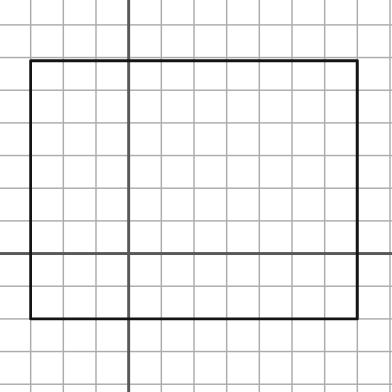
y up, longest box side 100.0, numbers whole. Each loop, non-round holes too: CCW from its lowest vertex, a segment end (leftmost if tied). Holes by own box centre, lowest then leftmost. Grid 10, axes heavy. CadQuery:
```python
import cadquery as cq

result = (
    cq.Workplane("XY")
    .moveTo(-30.0, -20.0)
    .lineTo(70.0, -20.0)
    .lineTo(70.0, 59.0)
    .lineTo(-30.0, 59.0)
    .close()
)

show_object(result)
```